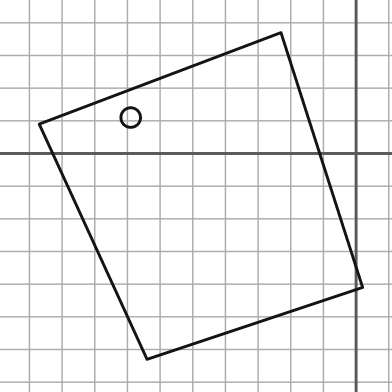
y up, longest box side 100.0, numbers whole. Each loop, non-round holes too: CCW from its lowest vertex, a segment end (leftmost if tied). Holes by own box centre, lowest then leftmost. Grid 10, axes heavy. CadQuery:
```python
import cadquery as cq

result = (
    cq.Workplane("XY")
    .moveTo(-64.0, -63.0)
    .lineTo(2.0, -41.0)
    .lineTo(-23.0, 37.0)
    .lineTo(-97.0, 9.0)
    .close()
    .moveTo(-69.0, 11.0)
    .circle(3.0)
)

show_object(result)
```